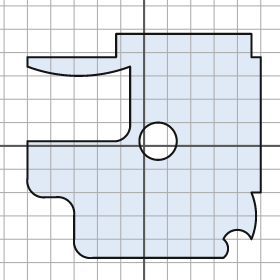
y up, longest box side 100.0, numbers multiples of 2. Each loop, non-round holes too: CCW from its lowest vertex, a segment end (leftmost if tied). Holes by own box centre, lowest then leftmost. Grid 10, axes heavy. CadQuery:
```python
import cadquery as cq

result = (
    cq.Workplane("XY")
    .moveTo(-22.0, -48.0)
    .lineTo(34.0, -48.0)
    .threePointArc((36.0, -44.0), (34.0, -40.0))
    .threePointArc((40.0, -36.0), (46.0, -40.0))
    .threePointArc((48.0, -30.0), (46.0, -20.0))
    .lineTo(50.0, -20.0)
    .lineTo(50.0, 38.0)
    .lineTo(46.0, 38.0)
    .lineTo(46.0, 48.0)
    .lineTo(-12.0, 48.0)
    .lineTo(-12.0, 38.0)
    .lineTo(-50.0, 38.0)
    .lineTo(-50.0, 34.0)
    .threePointArc((-28.0, 30.0), (-6.0, 34.0))
    .lineTo(-6.0, 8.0)
    .threePointArc((-8.0, 4.0), (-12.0, 2.0))
    .lineTo(-50.0, 2.0)
    .lineTo(-50.0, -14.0)
    .threePointArc((-48.0, -20.0), (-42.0, -22.0))
    .lineTo(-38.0, -22.0)
    .threePointArc((-32.0, -24.0), (-30.0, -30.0))
    .lineTo(-30.0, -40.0)
    .threePointArc((-28.0, -46.0), (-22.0, -48.0))
    .close()
    .moveTo(6.0, 2.0)
    .circle(8.0)
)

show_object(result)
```